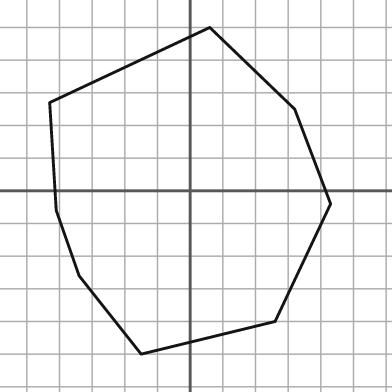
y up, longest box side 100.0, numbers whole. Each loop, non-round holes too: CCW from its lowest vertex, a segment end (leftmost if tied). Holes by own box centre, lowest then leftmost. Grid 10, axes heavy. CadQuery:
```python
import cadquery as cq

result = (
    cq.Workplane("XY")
    .moveTo(-15.0, -50.0)
    .lineTo(26.0, -40.0)
    .lineTo(43.0, -4.0)
    .lineTo(32.0, 25.0)
    .lineTo(6.0, 50.0)
    .lineTo(-43.0, 27.0)
    .lineTo(-41.0, -6.0)
    .lineTo(-34.0, -26.0)
    .close()
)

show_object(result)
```